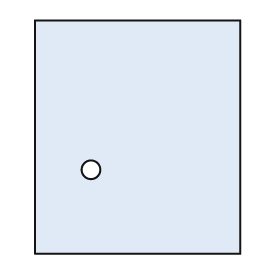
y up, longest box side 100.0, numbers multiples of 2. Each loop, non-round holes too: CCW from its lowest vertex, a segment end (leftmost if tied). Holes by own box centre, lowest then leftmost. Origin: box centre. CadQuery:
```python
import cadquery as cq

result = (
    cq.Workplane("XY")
    .moveTo(-44.0, -50.0)
    .lineTo(44.0, -50.0)
    .lineTo(44.0, 50.0)
    .lineTo(-44.0, 50.0)
    .close()
    .moveTo(-20.0, -14.0)
    .circle(4.0)
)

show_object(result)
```